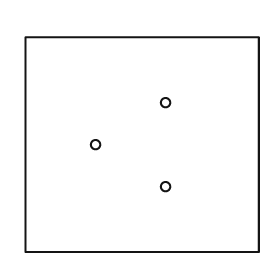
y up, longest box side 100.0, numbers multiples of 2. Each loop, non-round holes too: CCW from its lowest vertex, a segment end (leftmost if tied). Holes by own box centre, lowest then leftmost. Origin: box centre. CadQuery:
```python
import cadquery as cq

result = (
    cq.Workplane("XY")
    .moveTo(-50.0, -46.0)
    .lineTo(50.0, -46.0)
    .lineTo(50.0, 46.0)
    .lineTo(-50.0, 46.0)
    .close()
    .moveTo(10.0, -18.0)
    .circle(2.0)
    .moveTo(-20.0, 0.0)
    .circle(2.0)
    .moveTo(10.0, 18.0)
    .circle(2.0)
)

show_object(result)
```